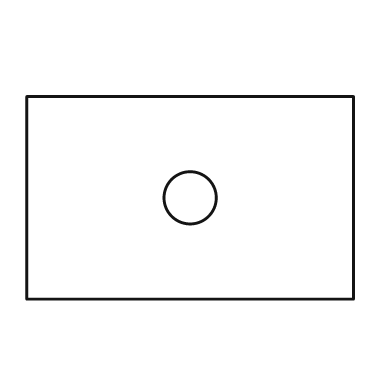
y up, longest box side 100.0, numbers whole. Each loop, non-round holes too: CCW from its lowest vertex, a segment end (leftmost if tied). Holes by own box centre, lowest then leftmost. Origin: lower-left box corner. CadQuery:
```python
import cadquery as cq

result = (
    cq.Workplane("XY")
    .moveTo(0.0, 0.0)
    .lineTo(100.0, 0.0)
    .lineTo(100.0, 62.0)
    .lineTo(0.0, 62.0)
    .close()
    .moveTo(50.0, 31.0)
    .circle(8.0)
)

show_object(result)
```